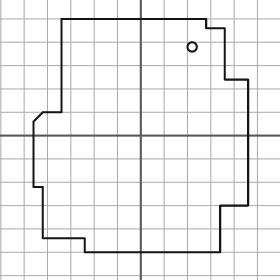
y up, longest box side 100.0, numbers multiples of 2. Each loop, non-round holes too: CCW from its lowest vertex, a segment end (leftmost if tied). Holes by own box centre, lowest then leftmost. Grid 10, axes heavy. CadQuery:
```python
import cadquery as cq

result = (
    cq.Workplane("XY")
    .moveTo(-24.0, -50.0)
    .lineTo(34.0, -50.0)
    .lineTo(34.0, -30.0)
    .lineTo(46.0, -30.0)
    .lineTo(46.0, 24.0)
    .lineTo(36.0, 24.0)
    .lineTo(36.0, 46.0)
    .lineTo(28.0, 46.0)
    .lineTo(28.0, 50.0)
    .lineTo(-34.0, 50.0)
    .lineTo(-34.0, 10.0)
    .lineTo(-42.0, 10.0)
    .lineTo(-46.0, 6.0)
    .lineTo(-46.0, -22.0)
    .lineTo(-42.0, -22.0)
    .lineTo(-42.0, -44.0)
    .lineTo(-24.0, -44.0)
    .close()
    .moveTo(22.0, 38.0)
    .circle(2.0)
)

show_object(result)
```